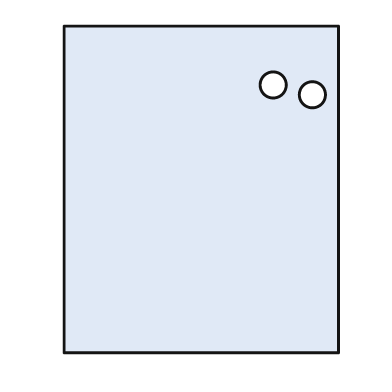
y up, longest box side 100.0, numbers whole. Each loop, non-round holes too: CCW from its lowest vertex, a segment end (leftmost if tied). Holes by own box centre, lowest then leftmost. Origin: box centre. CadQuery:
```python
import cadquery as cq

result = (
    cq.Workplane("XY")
    .moveTo(-42.0, -50.0)
    .lineTo(42.0, -50.0)
    .lineTo(42.0, 50.0)
    .lineTo(-42.0, 50.0)
    .close()
    .moveTo(34.0, 29.0)
    .circle(4.0)
    .moveTo(22.0, 32.0)
    .circle(4.0)
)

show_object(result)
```